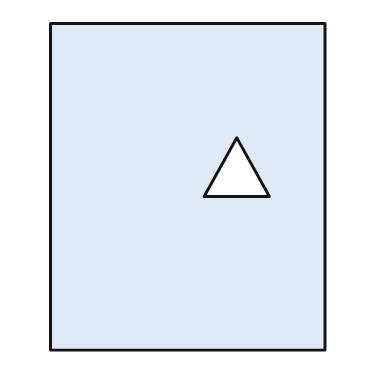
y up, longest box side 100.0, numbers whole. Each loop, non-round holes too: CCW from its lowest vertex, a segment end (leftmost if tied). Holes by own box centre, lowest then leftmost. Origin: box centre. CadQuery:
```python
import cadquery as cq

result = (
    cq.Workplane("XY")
    .moveTo(-42.0, -50.0)
    .lineTo(42.0, -50.0)
    .lineTo(42.0, 50.0)
    .lineTo(-42.0, 50.0)
    .close()
    .moveTo(5.0, -3.0)
    .lineTo(25.0, -3.0)
    .lineTo(15.0, 15.0)
    .close()
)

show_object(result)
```